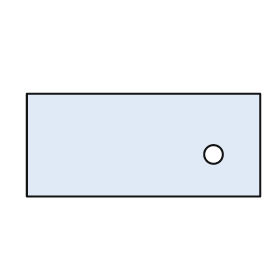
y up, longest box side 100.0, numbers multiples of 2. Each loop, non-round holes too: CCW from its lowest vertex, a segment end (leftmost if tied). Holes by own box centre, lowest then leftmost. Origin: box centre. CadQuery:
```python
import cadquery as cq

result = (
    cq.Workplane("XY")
    .moveTo(-50.0, -22.0)
    .lineTo(50.0, -22.0)
    .lineTo(50.0, 22.0)
    .lineTo(-50.0, 22.0)
    .close()
    .moveTo(30.0, -4.0)
    .circle(4.0)
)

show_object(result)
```